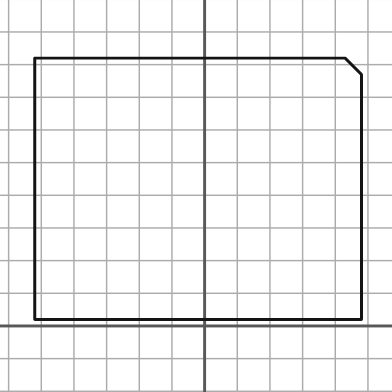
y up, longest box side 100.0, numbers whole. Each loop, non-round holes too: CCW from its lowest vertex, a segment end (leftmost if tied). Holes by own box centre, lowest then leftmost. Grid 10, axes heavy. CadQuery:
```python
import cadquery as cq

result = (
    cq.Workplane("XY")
    .moveTo(-52.0, 2.0)
    .lineTo(48.0, 2.0)
    .lineTo(48.0, 77.0)
    .lineTo(43.0, 82.0)
    .lineTo(-52.0, 82.0)
    .close()
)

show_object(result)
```